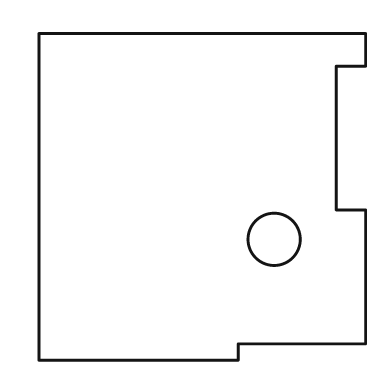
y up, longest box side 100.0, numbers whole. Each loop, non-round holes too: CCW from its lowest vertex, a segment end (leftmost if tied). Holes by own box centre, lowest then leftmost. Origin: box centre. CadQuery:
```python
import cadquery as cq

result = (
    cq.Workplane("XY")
    .moveTo(-50.0, -50.0)
    .lineTo(11.0, -50.0)
    .lineTo(11.0, -45.0)
    .lineTo(50.0, -45.0)
    .lineTo(50.0, -4.0)
    .lineTo(41.0, -4.0)
    .lineTo(41.0, 40.0)
    .lineTo(50.0, 40.0)
    .lineTo(50.0, 50.0)
    .lineTo(-50.0, 50.0)
    .close()
    .moveTo(22.0, -13.0)
    .circle(8.0)
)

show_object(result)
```